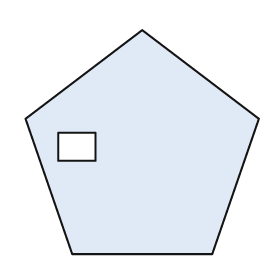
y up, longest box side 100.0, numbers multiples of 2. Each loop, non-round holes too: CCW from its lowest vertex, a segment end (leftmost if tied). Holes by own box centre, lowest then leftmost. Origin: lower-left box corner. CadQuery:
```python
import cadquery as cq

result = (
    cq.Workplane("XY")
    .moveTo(20.0, 0.0)
    .lineTo(80.0, 0.0)
    .lineTo(100.0, 58.0)
    .lineTo(50.0, 96.0)
    .lineTo(0.0, 58.0)
    .close()
    .moveTo(14.0, 40.0)
    .lineTo(30.0, 40.0)
    .lineTo(30.0, 52.0)
    .lineTo(14.0, 52.0)
    .close()
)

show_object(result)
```